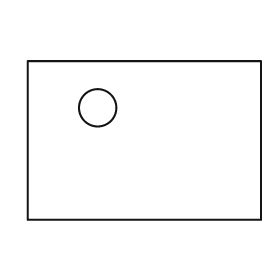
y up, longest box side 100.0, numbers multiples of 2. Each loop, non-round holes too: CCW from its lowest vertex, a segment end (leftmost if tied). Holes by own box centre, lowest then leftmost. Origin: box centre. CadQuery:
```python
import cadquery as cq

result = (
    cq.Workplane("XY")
    .moveTo(-50.0, -34.0)
    .lineTo(50.0, -34.0)
    .lineTo(50.0, 34.0)
    .lineTo(-50.0, 34.0)
    .close()
    .moveTo(-20.0, 14.0)
    .circle(8.0)
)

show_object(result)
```